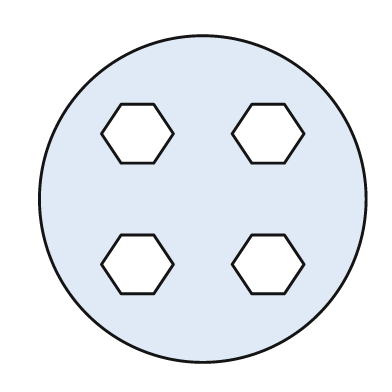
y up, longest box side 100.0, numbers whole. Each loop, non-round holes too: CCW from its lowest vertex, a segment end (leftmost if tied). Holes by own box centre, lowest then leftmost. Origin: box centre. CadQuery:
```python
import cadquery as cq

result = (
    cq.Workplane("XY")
    .moveTo(0.0, 0.0)
    .circle(50.0)
    .moveTo(-25.0, -29.0)
    .lineTo(-15.0, -29.0)
    .lineTo(-9.0, -20.0)
    .lineTo(-15.0, -11.0)
    .lineTo(-25.0, -11.0)
    .lineTo(-31.0, -20.0)
    .close()
    .moveTo(15.0, -29.0)
    .lineTo(25.0, -29.0)
    .lineTo(31.0, -20.0)
    .lineTo(25.0, -11.0)
    .lineTo(15.0, -11.0)
    .lineTo(9.0, -20.0)
    .close()
    .moveTo(-25.0, 11.0)
    .lineTo(-15.0, 11.0)
    .lineTo(-9.0, 20.0)
    .lineTo(-15.0, 29.0)
    .lineTo(-25.0, 29.0)
    .lineTo(-31.0, 20.0)
    .close()
    .moveTo(15.0, 11.0)
    .lineTo(25.0, 11.0)
    .lineTo(31.0, 20.0)
    .lineTo(25.0, 29.0)
    .lineTo(15.0, 29.0)
    .lineTo(9.0, 20.0)
    .close()
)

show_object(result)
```